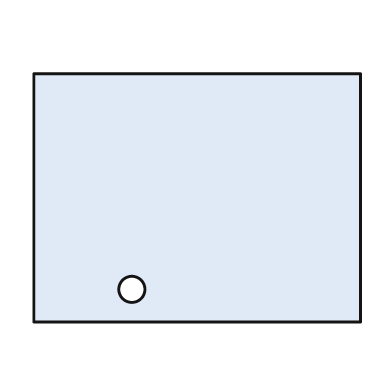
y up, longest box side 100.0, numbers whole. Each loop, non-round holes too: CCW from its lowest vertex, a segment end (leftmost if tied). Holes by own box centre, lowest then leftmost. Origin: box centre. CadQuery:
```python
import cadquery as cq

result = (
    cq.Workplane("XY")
    .moveTo(-50.0, -38.0)
    .lineTo(50.0, -38.0)
    .lineTo(50.0, 38.0)
    .lineTo(-50.0, 38.0)
    .close()
    .moveTo(-20.0, -28.0)
    .circle(4.0)
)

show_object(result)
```